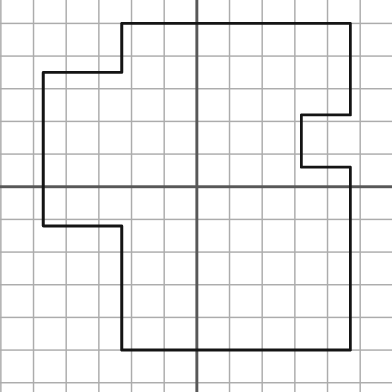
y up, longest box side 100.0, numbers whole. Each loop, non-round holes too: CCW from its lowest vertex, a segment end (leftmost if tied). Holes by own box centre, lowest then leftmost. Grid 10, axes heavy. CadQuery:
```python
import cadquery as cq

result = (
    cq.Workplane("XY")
    .moveTo(-23.0, -50.0)
    .lineTo(47.0, -50.0)
    .lineTo(47.0, 6.0)
    .lineTo(32.0, 6.0)
    .lineTo(32.0, 22.0)
    .lineTo(47.0, 22.0)
    .lineTo(47.0, 50.0)
    .lineTo(-23.0, 50.0)
    .lineTo(-23.0, 35.0)
    .lineTo(-47.0, 35.0)
    .lineTo(-47.0, -12.0)
    .lineTo(-23.0, -12.0)
    .close()
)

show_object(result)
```